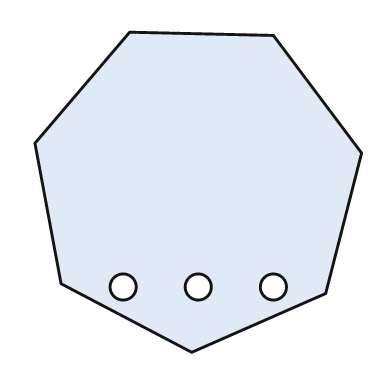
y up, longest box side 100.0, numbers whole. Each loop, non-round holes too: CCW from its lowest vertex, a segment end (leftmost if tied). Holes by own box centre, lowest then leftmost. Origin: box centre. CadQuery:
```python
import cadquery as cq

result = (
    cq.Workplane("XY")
    .moveTo(-2.0, -49.0)
    .lineTo(39.0, -31.0)
    .lineTo(50.0, 12.0)
    .lineTo(23.0, 48.0)
    .lineTo(-21.0, 49.0)
    .lineTo(-50.0, 15.0)
    .lineTo(-42.0, -28.0)
    .close()
    .moveTo(-23.0, -29.0)
    .circle(4.0)
    .moveTo(0.0, -29.0)
    .circle(4.0)
    .moveTo(23.0, -29.0)
    .circle(4.0)
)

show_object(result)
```